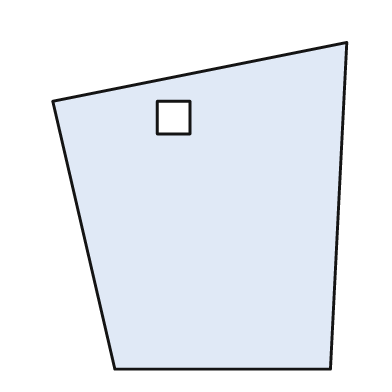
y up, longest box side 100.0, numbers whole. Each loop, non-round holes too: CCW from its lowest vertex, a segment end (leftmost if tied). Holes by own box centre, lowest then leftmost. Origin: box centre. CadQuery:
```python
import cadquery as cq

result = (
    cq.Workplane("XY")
    .moveTo(-26.0, -50.0)
    .lineTo(40.0, -50.0)
    .lineTo(45.0, 50.0)
    .lineTo(-45.0, 32.0)
    .close()
    .moveTo(-13.0, 22.0)
    .lineTo(-3.0, 22.0)
    .lineTo(-3.0, 32.0)
    .lineTo(-13.0, 32.0)
    .close()
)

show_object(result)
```